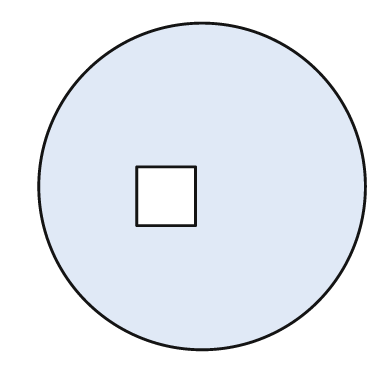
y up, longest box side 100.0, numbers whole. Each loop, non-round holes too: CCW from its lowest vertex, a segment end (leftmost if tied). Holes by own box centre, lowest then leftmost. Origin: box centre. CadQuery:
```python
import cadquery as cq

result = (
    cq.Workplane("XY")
    .moveTo(0.0, 0.0)
    .circle(50.0)
    .moveTo(-20.0, -12.0)
    .lineTo(-2.0, -12.0)
    .lineTo(-2.0, 6.0)
    .lineTo(-20.0, 6.0)
    .close()
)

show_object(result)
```